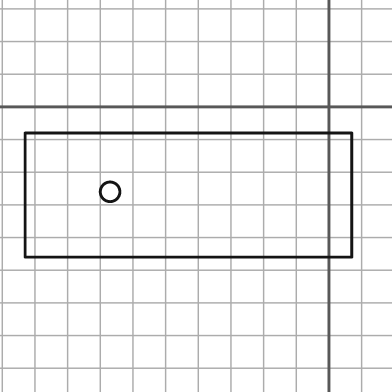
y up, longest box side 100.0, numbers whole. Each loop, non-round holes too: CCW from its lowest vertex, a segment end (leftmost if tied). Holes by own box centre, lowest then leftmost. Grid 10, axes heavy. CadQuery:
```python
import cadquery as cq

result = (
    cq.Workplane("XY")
    .moveTo(-93.0, -46.0)
    .lineTo(7.0, -46.0)
    .lineTo(7.0, -8.0)
    .lineTo(-93.0, -8.0)
    .close()
    .moveTo(-67.0, -26.0)
    .circle(3.0)
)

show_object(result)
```